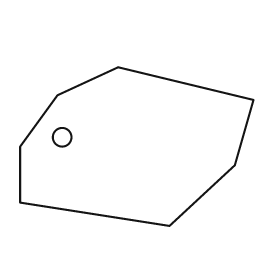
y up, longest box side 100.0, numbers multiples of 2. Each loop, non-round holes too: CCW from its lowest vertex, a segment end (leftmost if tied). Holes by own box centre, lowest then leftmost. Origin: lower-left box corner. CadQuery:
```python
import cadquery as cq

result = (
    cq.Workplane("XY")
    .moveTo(64.0, 0.0)
    .lineTo(92.0, 26.0)
    .lineTo(100.0, 54.0)
    .lineTo(42.0, 68.0)
    .lineTo(16.0, 56.0)
    .lineTo(0.0, 34.0)
    .lineTo(0.0, 10.0)
    .close()
    .moveTo(18.0, 38.0)
    .circle(4.0)
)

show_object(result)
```